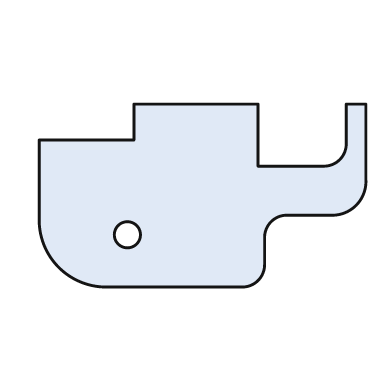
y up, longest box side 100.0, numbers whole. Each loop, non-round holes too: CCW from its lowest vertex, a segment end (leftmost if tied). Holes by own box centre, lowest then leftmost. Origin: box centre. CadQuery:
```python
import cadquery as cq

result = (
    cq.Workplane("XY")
    .moveTo(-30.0, -28.0)
    .lineTo(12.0, -28.0)
    .threePointArc((17.0, -26.0), (19.0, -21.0))
    .lineTo(19.0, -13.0)
    .threePointArc((21.0, -8.0), (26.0, -6.0))
    .lineTo(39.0, -6.0)
    .threePointArc((47.0, -3.0), (50.0, 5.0))
    .lineTo(50.0, 28.0)
    .lineTo(44.0, 28.0)
    .lineTo(44.0, 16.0)
    .threePointArc((42.0, 11.0), (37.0, 9.0))
    .lineTo(17.0, 9.0)
    .lineTo(17.0, 28.0)
    .lineTo(-21.0, 28.0)
    .lineTo(-21.0, 17.0)
    .lineTo(-50.0, 17.0)
    .lineTo(-50.0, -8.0)
    .threePointArc((-44.0, -22.0), (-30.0, -28.0))
    .close()
    .moveTo(-23.0, -12.0)
    .circle(4.0)
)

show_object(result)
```